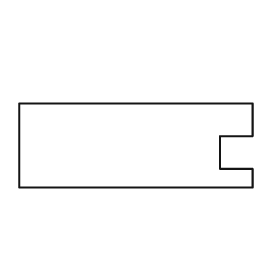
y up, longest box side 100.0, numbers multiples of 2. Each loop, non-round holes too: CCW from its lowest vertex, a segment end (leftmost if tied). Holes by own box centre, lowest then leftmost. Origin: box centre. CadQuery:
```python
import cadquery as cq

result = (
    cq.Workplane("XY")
    .moveTo(-50.0, -18.0)
    .lineTo(50.0, -18.0)
    .lineTo(50.0, -10.0)
    .lineTo(36.0, -10.0)
    .lineTo(36.0, 4.0)
    .lineTo(50.0, 4.0)
    .lineTo(50.0, 18.0)
    .lineTo(-50.0, 18.0)
    .close()
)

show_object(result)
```